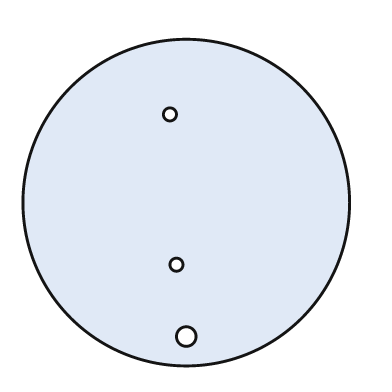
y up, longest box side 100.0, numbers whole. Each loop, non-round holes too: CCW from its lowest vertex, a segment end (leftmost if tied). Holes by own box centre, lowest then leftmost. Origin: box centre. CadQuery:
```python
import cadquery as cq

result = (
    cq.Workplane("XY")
    .moveTo(0.0, 0.0)
    .circle(50.0)
    .moveTo(0.0, -41.0)
    .circle(3.0)
    .moveTo(-3.0, -19.0)
    .circle(2.0)
    .moveTo(-5.0, 27.0)
    .circle(2.0)
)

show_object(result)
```